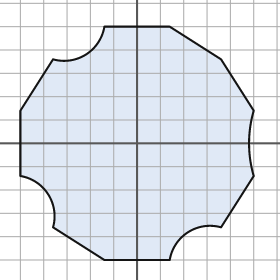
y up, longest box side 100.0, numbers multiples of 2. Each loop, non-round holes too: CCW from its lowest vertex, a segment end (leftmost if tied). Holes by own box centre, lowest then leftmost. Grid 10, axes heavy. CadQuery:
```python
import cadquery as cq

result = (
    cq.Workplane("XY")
    .moveTo(-14.0, -50.0)
    .lineTo(14.0, -50.0)
    .threePointArc((22.0, -38.0), (36.0, -36.0))
    .lineTo(50.0, -14.0)
    .threePointArc((48.0, 0.0), (50.0, 14.0))
    .lineTo(36.0, 36.0)
    .lineTo(14.0, 50.0)
    .lineTo(-14.0, 50.0)
    .threePointArc((-22.0, 38.0), (-36.0, 36.0))
    .lineTo(-50.0, 14.0)
    .lineTo(-50.0, -14.0)
    .threePointArc((-38.0, -22.0), (-36.0, -36.0))
    .close()
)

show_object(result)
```